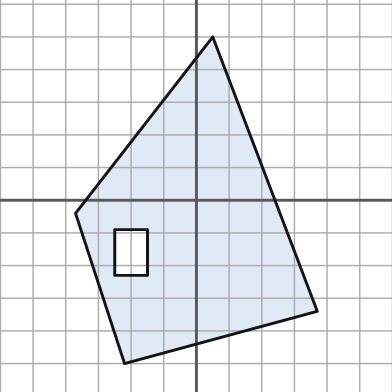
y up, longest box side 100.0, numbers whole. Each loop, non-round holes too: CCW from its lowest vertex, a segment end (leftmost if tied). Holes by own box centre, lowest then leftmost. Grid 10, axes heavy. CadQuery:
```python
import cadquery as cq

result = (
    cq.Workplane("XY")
    .moveTo(-22.0, -50.0)
    .lineTo(37.0, -34.0)
    .lineTo(5.0, 50.0)
    .lineTo(-37.0, -4.0)
    .close()
    .moveTo(-25.0, -23.0)
    .lineTo(-15.0, -23.0)
    .lineTo(-15.0, -9.0)
    .lineTo(-25.0, -9.0)
    .close()
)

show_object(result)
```